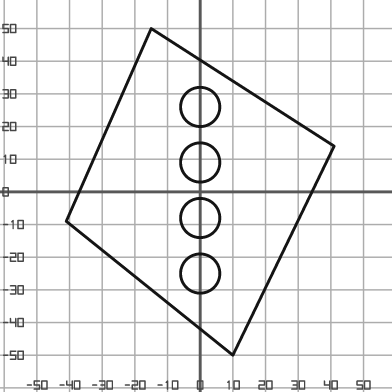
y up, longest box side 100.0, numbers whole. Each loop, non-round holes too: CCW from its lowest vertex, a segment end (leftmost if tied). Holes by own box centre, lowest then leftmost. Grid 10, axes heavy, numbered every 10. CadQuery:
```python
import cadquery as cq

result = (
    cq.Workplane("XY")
    .moveTo(10.0, -50.0)
    .lineTo(41.0, 14.0)
    .lineTo(-15.0, 50.0)
    .lineTo(-41.0, -9.0)
    .close()
    .moveTo(0.0, -25.0)
    .circle(6.0)
    .moveTo(0.0, -8.0)
    .circle(6.0)
    .moveTo(0.0, 9.0)
    .circle(6.0)
    .moveTo(0.0, 26.0)
    .circle(6.0)
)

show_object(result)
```